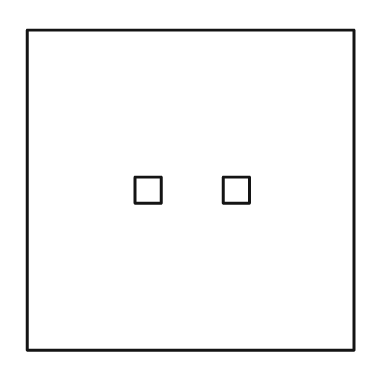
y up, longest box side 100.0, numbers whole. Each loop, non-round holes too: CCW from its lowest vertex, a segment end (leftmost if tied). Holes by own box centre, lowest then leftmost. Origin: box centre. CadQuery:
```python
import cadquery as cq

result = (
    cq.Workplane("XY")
    .moveTo(-50.0, -49.0)
    .lineTo(50.0, -49.0)
    .lineTo(50.0, 49.0)
    .lineTo(-50.0, 49.0)
    .close()
    .moveTo(-17.0, -4.0)
    .lineTo(-9.0, -4.0)
    .lineTo(-9.0, 4.0)
    .lineTo(-17.0, 4.0)
    .close()
    .moveTo(10.0, -4.0)
    .lineTo(18.0, -4.0)
    .lineTo(18.0, 4.0)
    .lineTo(10.0, 4.0)
    .close()
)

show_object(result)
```